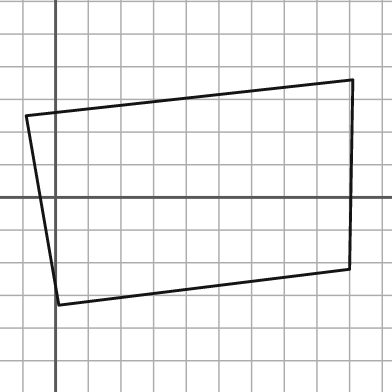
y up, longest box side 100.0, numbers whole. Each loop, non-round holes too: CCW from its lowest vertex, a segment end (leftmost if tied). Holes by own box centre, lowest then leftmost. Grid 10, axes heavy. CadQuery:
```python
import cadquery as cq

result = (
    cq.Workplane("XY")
    .moveTo(1.0, -33.0)
    .lineTo(90.0, -22.0)
    .lineTo(91.0, 36.0)
    .lineTo(-9.0, 25.0)
    .close()
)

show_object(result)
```